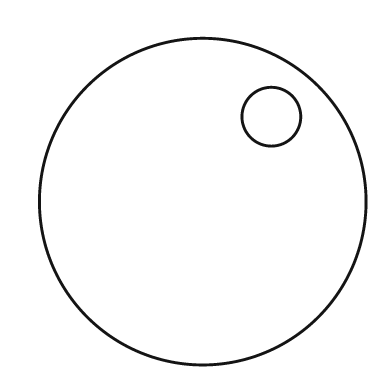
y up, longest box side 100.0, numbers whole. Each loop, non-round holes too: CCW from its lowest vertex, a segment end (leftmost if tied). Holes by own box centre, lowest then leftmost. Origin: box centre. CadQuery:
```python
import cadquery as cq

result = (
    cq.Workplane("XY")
    .moveTo(0.0, 0.0)
    .circle(50.0)
    .moveTo(21.0, 26.0)
    .circle(9.0)
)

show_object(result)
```